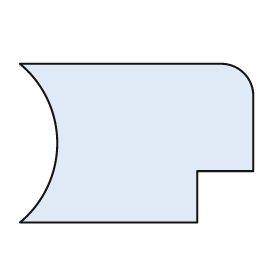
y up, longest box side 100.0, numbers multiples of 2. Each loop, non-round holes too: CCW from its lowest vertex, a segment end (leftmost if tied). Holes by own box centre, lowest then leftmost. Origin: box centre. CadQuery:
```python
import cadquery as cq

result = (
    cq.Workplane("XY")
    .moveTo(-50.0, -34.0)
    .lineTo(26.0, -34.0)
    .lineTo(26.0, -12.0)
    .lineTo(50.0, -12.0)
    .lineTo(50.0, 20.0)
    .threePointArc((46.0, 30.0), (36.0, 34.0))
    .lineTo(-50.0, 34.0)
    .threePointArc((-34.0, 0.0), (-50.0, -34.0))
    .close()
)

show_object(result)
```